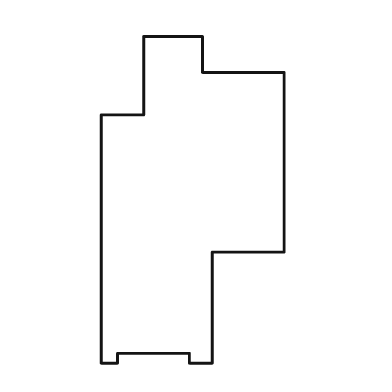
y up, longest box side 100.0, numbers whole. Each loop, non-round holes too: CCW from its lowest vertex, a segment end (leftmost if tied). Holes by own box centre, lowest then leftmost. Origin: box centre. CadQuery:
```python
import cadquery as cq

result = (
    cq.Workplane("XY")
    .moveTo(-28.0, -50.0)
    .lineTo(-23.0, -50.0)
    .lineTo(-23.0, -47.0)
    .lineTo(-1.0, -47.0)
    .lineTo(-1.0, -50.0)
    .lineTo(6.0, -50.0)
    .lineTo(6.0, -16.0)
    .lineTo(28.0, -16.0)
    .lineTo(28.0, 39.0)
    .lineTo(3.0, 39.0)
    .lineTo(3.0, 50.0)
    .lineTo(-15.0, 50.0)
    .lineTo(-15.0, 26.0)
    .lineTo(-28.0, 26.0)
    .close()
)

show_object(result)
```